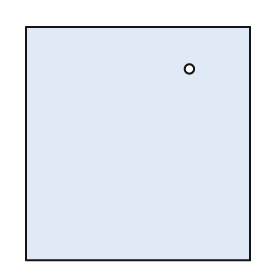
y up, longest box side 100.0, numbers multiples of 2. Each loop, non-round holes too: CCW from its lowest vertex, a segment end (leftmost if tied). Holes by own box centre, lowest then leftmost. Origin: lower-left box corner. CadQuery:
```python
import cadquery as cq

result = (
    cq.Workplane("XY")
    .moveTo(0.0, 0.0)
    .lineTo(96.0, 0.0)
    .lineTo(96.0, 100.0)
    .lineTo(0.0, 100.0)
    .close()
    .moveTo(70.0, 82.0)
    .circle(2.0)
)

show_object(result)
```